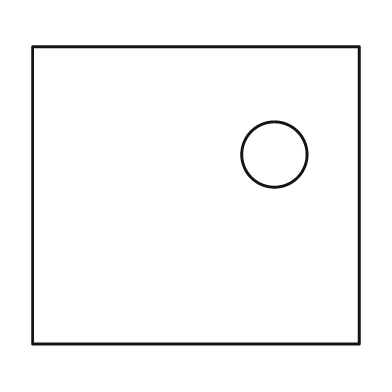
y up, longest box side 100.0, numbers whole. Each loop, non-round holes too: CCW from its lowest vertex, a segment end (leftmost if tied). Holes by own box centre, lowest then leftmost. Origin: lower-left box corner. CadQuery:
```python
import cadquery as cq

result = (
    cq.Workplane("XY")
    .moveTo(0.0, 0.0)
    .lineTo(100.0, 0.0)
    .lineTo(100.0, 91.0)
    .lineTo(0.0, 91.0)
    .close()
    .moveTo(74.0, 58.0)
    .circle(10.0)
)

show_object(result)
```